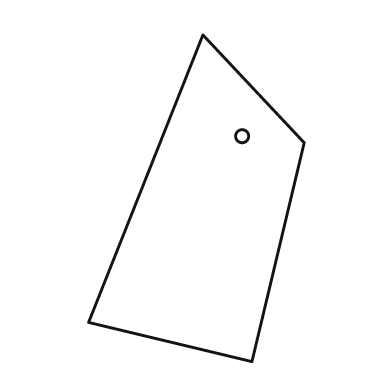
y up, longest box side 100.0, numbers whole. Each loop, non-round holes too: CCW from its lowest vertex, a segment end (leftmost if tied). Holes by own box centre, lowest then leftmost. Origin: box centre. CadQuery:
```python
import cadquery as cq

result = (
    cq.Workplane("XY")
    .moveTo(17.0, -50.0)
    .lineTo(33.0, 17.0)
    .lineTo(2.0, 50.0)
    .lineTo(-33.0, -38.0)
    .close()
    .moveTo(14.0, 19.0)
    .circle(2.0)
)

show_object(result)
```